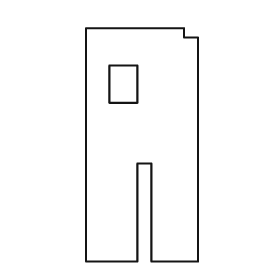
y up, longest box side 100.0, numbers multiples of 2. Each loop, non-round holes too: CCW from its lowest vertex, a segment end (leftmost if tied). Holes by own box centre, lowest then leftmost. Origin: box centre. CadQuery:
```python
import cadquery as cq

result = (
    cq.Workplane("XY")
    .moveTo(-24.0, -50.0)
    .lineTo(-2.0, -50.0)
    .lineTo(-2.0, -8.0)
    .lineTo(4.0, -8.0)
    .lineTo(4.0, -50.0)
    .lineTo(24.0, -50.0)
    .lineTo(24.0, 46.0)
    .lineTo(18.0, 46.0)
    .lineTo(18.0, 50.0)
    .lineTo(-24.0, 50.0)
    .close()
    .moveTo(-14.0, 18.0)
    .lineTo(-2.0, 18.0)
    .lineTo(-2.0, 34.0)
    .lineTo(-14.0, 34.0)
    .close()
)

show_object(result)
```